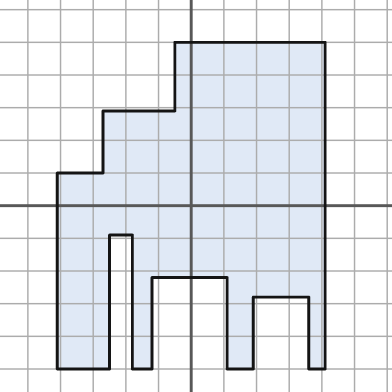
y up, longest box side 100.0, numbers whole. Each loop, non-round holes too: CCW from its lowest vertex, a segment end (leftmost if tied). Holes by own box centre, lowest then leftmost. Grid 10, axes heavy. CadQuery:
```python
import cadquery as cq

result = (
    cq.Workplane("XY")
    .moveTo(-41.0, -50.0)
    .lineTo(-25.0, -50.0)
    .lineTo(-25.0, -9.0)
    .lineTo(-18.0, -9.0)
    .lineTo(-18.0, -50.0)
    .lineTo(-12.0, -50.0)
    .lineTo(-12.0, -22.0)
    .lineTo(11.0, -22.0)
    .lineTo(11.0, -50.0)
    .lineTo(19.0, -50.0)
    .lineTo(19.0, -28.0)
    .lineTo(36.0, -28.0)
    .lineTo(36.0, -50.0)
    .lineTo(41.0, -50.0)
    .lineTo(41.0, 50.0)
    .lineTo(-5.0, 50.0)
    .lineTo(-5.0, 29.0)
    .lineTo(-27.0, 29.0)
    .lineTo(-27.0, 10.0)
    .lineTo(-41.0, 10.0)
    .close()
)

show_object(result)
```